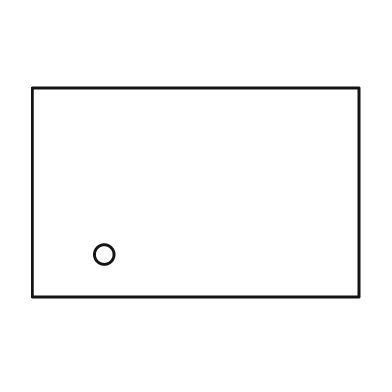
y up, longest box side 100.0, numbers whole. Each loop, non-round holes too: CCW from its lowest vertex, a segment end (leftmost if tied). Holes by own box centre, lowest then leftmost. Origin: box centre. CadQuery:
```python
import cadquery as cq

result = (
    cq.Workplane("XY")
    .moveTo(-50.0, -32.0)
    .lineTo(50.0, -32.0)
    .lineTo(50.0, 32.0)
    .lineTo(-50.0, 32.0)
    .close()
    .moveTo(-28.0, -19.0)
    .circle(3.0)
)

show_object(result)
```